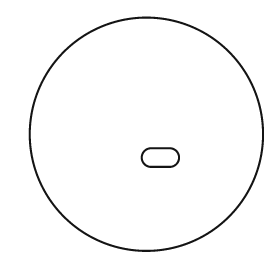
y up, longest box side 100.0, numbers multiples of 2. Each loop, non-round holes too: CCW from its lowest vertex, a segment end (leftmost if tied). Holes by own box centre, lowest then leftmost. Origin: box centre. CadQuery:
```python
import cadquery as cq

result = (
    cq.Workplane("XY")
    .moveTo(0.0, 0.0)
    .circle(50.0)
    .moveTo(2.0, -14.0)
    .lineTo(10.0, -14.0)
    .threePointArc((14.0, -10.0), (10.0, -6.0))
    .lineTo(2.0, -6.0)
    .threePointArc((-2.0, -10.0), (2.0, -14.0))
    .close()
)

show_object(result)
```